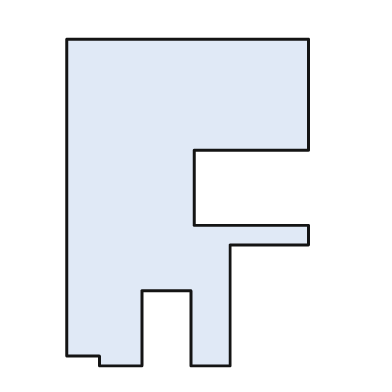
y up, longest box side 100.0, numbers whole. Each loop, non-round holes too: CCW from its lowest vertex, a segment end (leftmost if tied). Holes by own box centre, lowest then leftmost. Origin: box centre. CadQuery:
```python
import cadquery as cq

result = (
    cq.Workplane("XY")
    .moveTo(-27.0, -50.0)
    .lineTo(-14.0, -50.0)
    .lineTo(-14.0, -27.0)
    .lineTo(1.0, -27.0)
    .lineTo(1.0, -50.0)
    .lineTo(13.0, -50.0)
    .lineTo(13.0, -13.0)
    .lineTo(37.0, -13.0)
    .lineTo(37.0, -7.0)
    .lineTo(2.0, -7.0)
    .lineTo(2.0, 16.0)
    .lineTo(37.0, 16.0)
    .lineTo(37.0, 50.0)
    .lineTo(-37.0, 50.0)
    .lineTo(-37.0, -47.0)
    .lineTo(-27.0, -47.0)
    .close()
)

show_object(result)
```